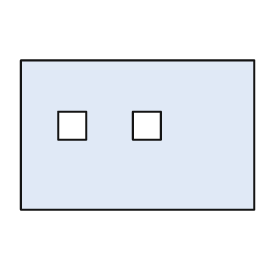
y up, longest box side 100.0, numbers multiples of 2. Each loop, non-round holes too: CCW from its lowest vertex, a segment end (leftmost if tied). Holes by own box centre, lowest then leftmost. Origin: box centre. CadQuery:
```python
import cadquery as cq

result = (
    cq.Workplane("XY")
    .moveTo(-50.0, -32.0)
    .lineTo(50.0, -32.0)
    .lineTo(50.0, 32.0)
    .lineTo(-50.0, 32.0)
    .close()
    .moveTo(-34.0, -2.0)
    .lineTo(-22.0, -2.0)
    .lineTo(-22.0, 10.0)
    .lineTo(-34.0, 10.0)
    .close()
    .moveTo(-2.0, -2.0)
    .lineTo(10.0, -2.0)
    .lineTo(10.0, 10.0)
    .lineTo(-2.0, 10.0)
    .close()
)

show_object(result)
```